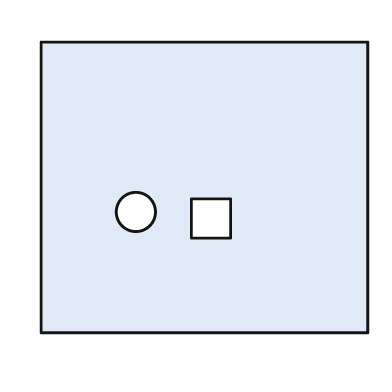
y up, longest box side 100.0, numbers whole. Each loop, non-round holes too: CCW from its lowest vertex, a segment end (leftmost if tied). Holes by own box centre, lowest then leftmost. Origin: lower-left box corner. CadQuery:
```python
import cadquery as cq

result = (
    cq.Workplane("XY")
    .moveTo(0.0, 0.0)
    .lineTo(100.0, 0.0)
    .lineTo(100.0, 89.0)
    .lineTo(0.0, 89.0)
    .close()
    .moveTo(46.0, 29.0)
    .lineTo(58.0, 29.0)
    .lineTo(58.0, 41.0)
    .lineTo(46.0, 41.0)
    .close()
    .moveTo(29.0, 37.0)
    .circle(6.0)
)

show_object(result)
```